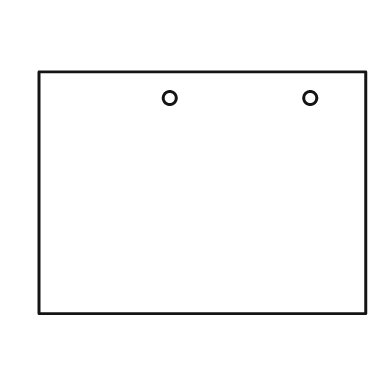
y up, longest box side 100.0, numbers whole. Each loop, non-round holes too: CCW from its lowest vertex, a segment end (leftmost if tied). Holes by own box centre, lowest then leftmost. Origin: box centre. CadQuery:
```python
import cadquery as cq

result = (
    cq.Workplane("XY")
    .moveTo(-50.0, -37.0)
    .lineTo(50.0, -37.0)
    .lineTo(50.0, 37.0)
    .lineTo(-50.0, 37.0)
    .close()
    .moveTo(-10.0, 29.0)
    .circle(2.0)
    .moveTo(33.0, 29.0)
    .circle(2.0)
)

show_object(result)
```